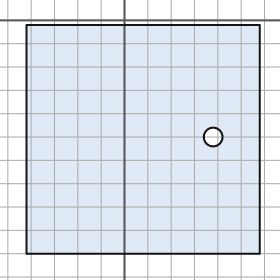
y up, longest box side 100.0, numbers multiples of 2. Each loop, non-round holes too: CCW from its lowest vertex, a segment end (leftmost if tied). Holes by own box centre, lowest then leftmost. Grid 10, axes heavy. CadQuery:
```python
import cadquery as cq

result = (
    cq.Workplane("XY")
    .moveTo(-42.0, -100.0)
    .lineTo(58.0, -100.0)
    .lineTo(58.0, -2.0)
    .lineTo(-42.0, -2.0)
    .close()
    .moveTo(38.0, -50.0)
    .circle(4.0)
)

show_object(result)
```